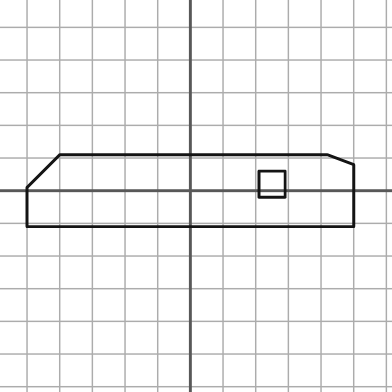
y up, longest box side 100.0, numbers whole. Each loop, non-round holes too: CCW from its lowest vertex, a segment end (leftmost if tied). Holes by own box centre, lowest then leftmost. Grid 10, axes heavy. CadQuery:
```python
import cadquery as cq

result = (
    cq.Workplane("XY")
    .moveTo(-50.0, -11.0)
    .lineTo(50.0, -11.0)
    .lineTo(50.0, 8.0)
    .lineTo(42.0, 11.0)
    .lineTo(-40.0, 11.0)
    .lineTo(-50.0, 1.0)
    .close()
    .moveTo(21.0, -2.0)
    .lineTo(29.0, -2.0)
    .lineTo(29.0, 6.0)
    .lineTo(21.0, 6.0)
    .close()
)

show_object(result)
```